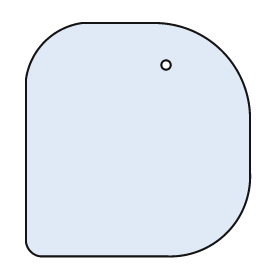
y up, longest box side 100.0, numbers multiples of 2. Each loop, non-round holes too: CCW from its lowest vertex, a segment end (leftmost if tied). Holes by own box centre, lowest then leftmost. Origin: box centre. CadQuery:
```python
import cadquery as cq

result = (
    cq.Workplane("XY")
    .moveTo(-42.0, -50.0)
    .lineTo(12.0, -50.0)
    .threePointArc((38.0, -40.0), (48.0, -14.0))
    .lineTo(48.0, 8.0)
    .threePointArc((36.0, 38.0), (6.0, 50.0))
    .lineTo(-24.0, 50.0)
    .threePointArc((-40.0, 42.0), (-48.0, 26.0))
    .lineTo(-48.0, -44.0)
    .threePointArc((-46.0, -48.0), (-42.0, -50.0))
    .close()
    .moveTo(12.0, 32.0)
    .circle(2.0)
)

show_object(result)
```